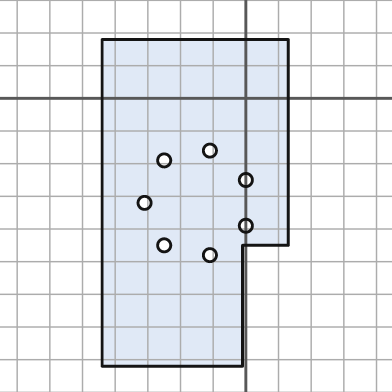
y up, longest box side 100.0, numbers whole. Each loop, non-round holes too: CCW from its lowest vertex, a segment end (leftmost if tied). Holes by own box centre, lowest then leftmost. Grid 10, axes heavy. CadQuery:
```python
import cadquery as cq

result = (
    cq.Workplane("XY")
    .moveTo(-44.0, -82.0)
    .lineTo(-1.0, -82.0)
    .lineTo(-1.0, -45.0)
    .lineTo(13.0, -45.0)
    .lineTo(13.0, 18.0)
    .lineTo(-44.0, 18.0)
    .close()
    .moveTo(-11.0, -48.0)
    .circle(2.0)
    .moveTo(-25.0, -45.0)
    .circle(2.0)
    .moveTo(0.0, -39.0)
    .circle(2.0)
    .moveTo(-31.0, -32.0)
    .circle(2.0)
    .moveTo(0.0, -25.0)
    .circle(2.0)
    .moveTo(-25.0, -19.0)
    .circle(2.0)
    .moveTo(-11.0, -16.0)
    .circle(2.0)
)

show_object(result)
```